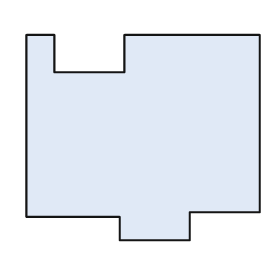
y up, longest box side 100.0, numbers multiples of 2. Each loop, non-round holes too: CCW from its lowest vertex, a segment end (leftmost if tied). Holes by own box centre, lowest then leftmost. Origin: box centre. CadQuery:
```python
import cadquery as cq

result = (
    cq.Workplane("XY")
    .moveTo(-10.0, -44.0)
    .lineTo(20.0, -44.0)
    .lineTo(20.0, -32.0)
    .lineTo(50.0, -32.0)
    .lineTo(50.0, 44.0)
    .lineTo(-8.0, 44.0)
    .lineTo(-8.0, 28.0)
    .lineTo(-38.0, 28.0)
    .lineTo(-38.0, 44.0)
    .lineTo(-50.0, 44.0)
    .lineTo(-50.0, -34.0)
    .lineTo(-10.0, -34.0)
    .close()
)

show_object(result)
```